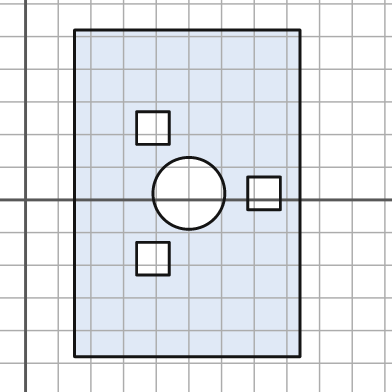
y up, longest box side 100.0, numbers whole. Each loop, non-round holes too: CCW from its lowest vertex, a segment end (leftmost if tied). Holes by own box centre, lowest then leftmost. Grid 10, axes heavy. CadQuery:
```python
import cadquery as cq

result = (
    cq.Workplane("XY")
    .moveTo(15.0, -48.0)
    .lineTo(84.0, -48.0)
    .lineTo(84.0, 52.0)
    .lineTo(15.0, 52.0)
    .close()
    .moveTo(34.0, -23.0)
    .lineTo(44.0, -23.0)
    .lineTo(44.0, -13.0)
    .lineTo(34.0, -13.0)
    .close()
    .moveTo(50.0, 2.0)
    .circle(11.0)
    .moveTo(68.0, -3.0)
    .lineTo(78.0, -3.0)
    .lineTo(78.0, 7.0)
    .lineTo(68.0, 7.0)
    .close()
    .moveTo(34.0, 17.0)
    .lineTo(44.0, 17.0)
    .lineTo(44.0, 27.0)
    .lineTo(34.0, 27.0)
    .close()
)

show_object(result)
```